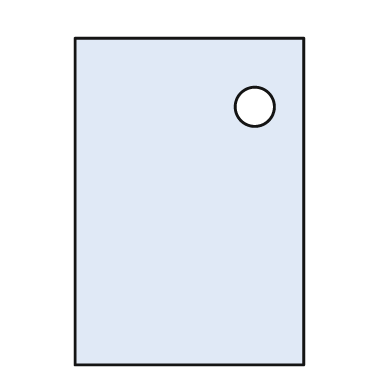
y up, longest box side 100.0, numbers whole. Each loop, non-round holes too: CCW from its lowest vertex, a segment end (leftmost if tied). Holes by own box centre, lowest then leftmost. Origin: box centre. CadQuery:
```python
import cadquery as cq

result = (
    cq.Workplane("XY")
    .moveTo(-35.0, -50.0)
    .lineTo(35.0, -50.0)
    .lineTo(35.0, 50.0)
    .lineTo(-35.0, 50.0)
    .close()
    .moveTo(20.0, 29.0)
    .circle(6.0)
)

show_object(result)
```